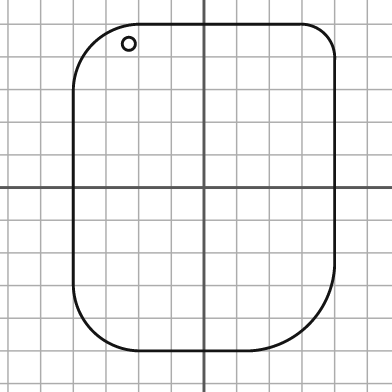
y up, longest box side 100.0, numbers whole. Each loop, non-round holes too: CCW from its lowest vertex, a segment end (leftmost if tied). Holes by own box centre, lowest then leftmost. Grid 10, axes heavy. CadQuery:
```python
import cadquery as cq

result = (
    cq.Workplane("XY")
    .moveTo(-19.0, -50.0)
    .lineTo(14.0, -50.0)
    .threePointArc((32.0, -42.0), (40.0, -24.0))
    .lineTo(40.0, 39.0)
    .threePointArc((37.0, 47.0), (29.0, 50.0))
    .lineTo(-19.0, 50.0)
    .threePointArc((-34.0, 44.0), (-40.0, 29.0))
    .lineTo(-40.0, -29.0)
    .threePointArc((-34.0, -44.0), (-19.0, -50.0))
    .close()
    .moveTo(-23.0, 44.0)
    .circle(2.0)
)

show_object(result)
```